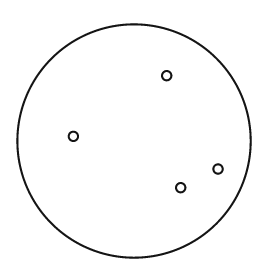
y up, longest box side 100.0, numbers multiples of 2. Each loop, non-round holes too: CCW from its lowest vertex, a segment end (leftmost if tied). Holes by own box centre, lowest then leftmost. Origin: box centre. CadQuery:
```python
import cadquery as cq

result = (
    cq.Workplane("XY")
    .moveTo(0.0, 0.0)
    .circle(50.0)
    .moveTo(20.0, -20.0)
    .circle(2.0)
    .moveTo(36.0, -12.0)
    .circle(2.0)
    .moveTo(-26.0, 2.0)
    .circle(2.0)
    .moveTo(14.0, 28.0)
    .circle(2.0)
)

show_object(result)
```